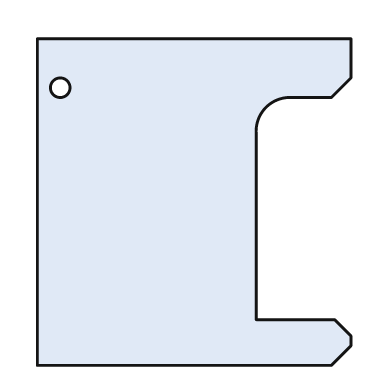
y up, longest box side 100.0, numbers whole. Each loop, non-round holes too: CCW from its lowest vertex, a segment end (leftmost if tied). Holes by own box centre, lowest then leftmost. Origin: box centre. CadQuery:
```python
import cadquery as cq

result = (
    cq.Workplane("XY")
    .moveTo(-48.0, -50.0)
    .lineTo(42.0, -50.0)
    .lineTo(48.0, -44.0)
    .lineTo(48.0, -41.0)
    .lineTo(43.0, -36.0)
    .lineTo(19.0, -36.0)
    .lineTo(19.0, 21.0)
    .threePointArc((22.0, 29.0), (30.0, 32.0))
    .lineTo(42.0, 32.0)
    .lineTo(48.0, 38.0)
    .lineTo(48.0, 50.0)
    .lineTo(-48.0, 50.0)
    .close()
    .moveTo(-41.0, 35.0)
    .circle(3.0)
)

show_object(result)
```